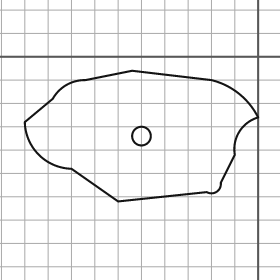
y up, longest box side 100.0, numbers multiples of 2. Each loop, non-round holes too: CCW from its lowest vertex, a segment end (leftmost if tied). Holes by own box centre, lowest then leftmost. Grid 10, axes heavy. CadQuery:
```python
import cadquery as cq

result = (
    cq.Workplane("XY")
    .moveTo(-60.0, -62.0)
    .lineTo(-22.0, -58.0)
    .threePointArc((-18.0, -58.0), (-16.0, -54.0))
    .lineTo(-10.0, -42.0)
    .threePointArc((-8.0, -32.0), (0.0, -26.0))
    .threePointArc((-8.0, -16.0), (-20.0, -10.0))
    .lineTo(-54.0, -6.0)
    .lineTo(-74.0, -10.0)
    .threePointArc((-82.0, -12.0), (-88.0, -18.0))
    .lineTo(-100.0, -28.0)
    .threePointArc((-94.0, -42.0), (-80.0, -48.0))
    .close()
    .moveTo(-50.0, -34.0)
    .circle(4.0)
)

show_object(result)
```